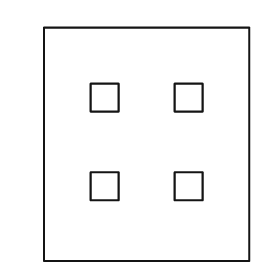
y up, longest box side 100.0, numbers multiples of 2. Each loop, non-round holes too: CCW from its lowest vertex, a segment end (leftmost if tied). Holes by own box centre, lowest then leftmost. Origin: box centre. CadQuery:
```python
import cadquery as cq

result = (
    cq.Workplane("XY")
    .moveTo(-44.0, -50.0)
    .lineTo(44.0, -50.0)
    .lineTo(44.0, 50.0)
    .lineTo(-44.0, 50.0)
    .close()
    .moveTo(-24.0, -24.0)
    .lineTo(-12.0, -24.0)
    .lineTo(-12.0, -12.0)
    .lineTo(-24.0, -12.0)
    .close()
    .moveTo(12.0, -24.0)
    .lineTo(24.0, -24.0)
    .lineTo(24.0, -12.0)
    .lineTo(12.0, -12.0)
    .close()
    .moveTo(-24.0, 14.0)
    .lineTo(-12.0, 14.0)
    .lineTo(-12.0, 26.0)
    .lineTo(-24.0, 26.0)
    .close()
    .moveTo(12.0, 14.0)
    .lineTo(24.0, 14.0)
    .lineTo(24.0, 26.0)
    .lineTo(12.0, 26.0)
    .close()
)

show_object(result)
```